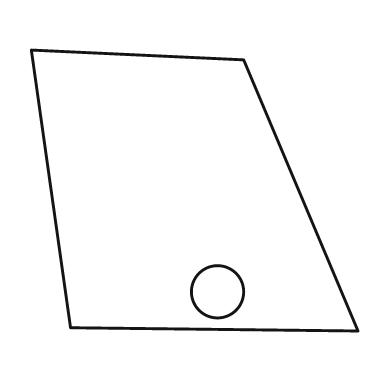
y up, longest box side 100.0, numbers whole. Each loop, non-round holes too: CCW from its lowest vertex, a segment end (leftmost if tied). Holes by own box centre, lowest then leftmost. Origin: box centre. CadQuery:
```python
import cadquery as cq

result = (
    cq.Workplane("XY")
    .moveTo(50.0, -43.0)
    .lineTo(15.0, 40.0)
    .lineTo(-50.0, 43.0)
    .lineTo(-38.0, -42.0)
    .close()
    .moveTo(7.0, -31.0)
    .circle(8.0)
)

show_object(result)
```